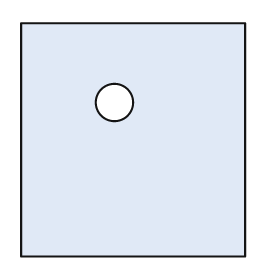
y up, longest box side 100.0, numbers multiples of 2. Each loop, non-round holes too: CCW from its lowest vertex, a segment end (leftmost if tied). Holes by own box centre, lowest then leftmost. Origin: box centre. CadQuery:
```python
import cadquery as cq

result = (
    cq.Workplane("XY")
    .moveTo(-48.0, -50.0)
    .lineTo(48.0, -50.0)
    .lineTo(48.0, 50.0)
    .lineTo(-48.0, 50.0)
    .close()
    .moveTo(-8.0, 16.0)
    .circle(8.0)
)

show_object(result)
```